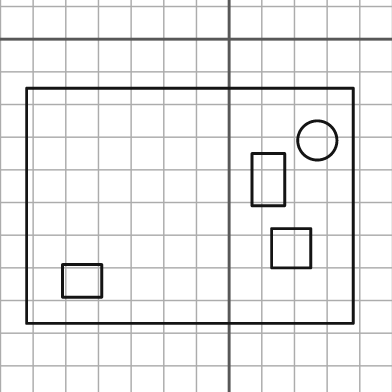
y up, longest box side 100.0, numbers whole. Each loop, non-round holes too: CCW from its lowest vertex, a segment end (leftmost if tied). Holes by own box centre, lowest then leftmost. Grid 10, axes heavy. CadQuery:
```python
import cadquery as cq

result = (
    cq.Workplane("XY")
    .moveTo(-62.0, -87.0)
    .lineTo(38.0, -87.0)
    .lineTo(38.0, -15.0)
    .lineTo(-62.0, -15.0)
    .close()
    .moveTo(-51.0, -79.0)
    .lineTo(-39.0, -79.0)
    .lineTo(-39.0, -69.0)
    .lineTo(-51.0, -69.0)
    .close()
    .moveTo(13.0, -70.0)
    .lineTo(25.0, -70.0)
    .lineTo(25.0, -58.0)
    .lineTo(13.0, -58.0)
    .close()
    .moveTo(7.0, -51.0)
    .lineTo(17.0, -51.0)
    .lineTo(17.0, -35.0)
    .lineTo(7.0, -35.0)
    .close()
    .moveTo(27.0, -31.0)
    .circle(6.0)
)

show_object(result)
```